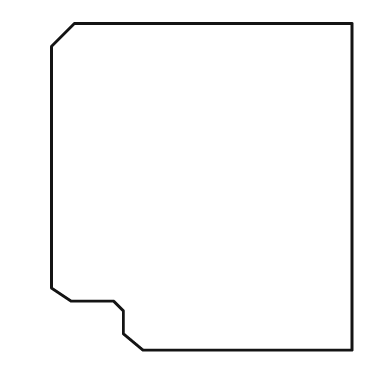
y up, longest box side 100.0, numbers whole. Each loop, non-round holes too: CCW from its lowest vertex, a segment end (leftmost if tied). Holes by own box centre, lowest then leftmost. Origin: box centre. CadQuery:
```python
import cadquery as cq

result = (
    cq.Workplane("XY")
    .moveTo(-18.0, -50.0)
    .lineTo(46.0, -50.0)
    .lineTo(46.0, 50.0)
    .lineTo(-39.0, 50.0)
    .lineTo(-46.0, 43.0)
    .lineTo(-46.0, -31.0)
    .lineTo(-40.0, -35.0)
    .lineTo(-27.0, -35.0)
    .lineTo(-24.0, -38.0)
    .lineTo(-24.0, -45.0)
    .close()
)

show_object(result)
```